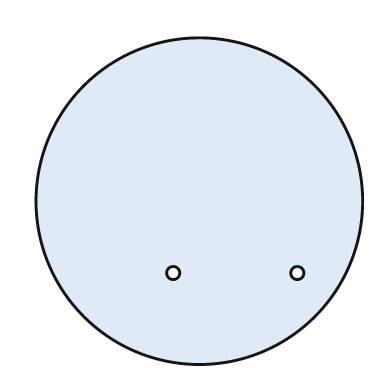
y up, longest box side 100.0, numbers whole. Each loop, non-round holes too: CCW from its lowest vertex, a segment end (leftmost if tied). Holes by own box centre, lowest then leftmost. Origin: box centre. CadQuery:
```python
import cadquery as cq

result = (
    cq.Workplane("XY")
    .moveTo(0.0, 0.0)
    .circle(50.0)
    .moveTo(-8.0, -22.0)
    .circle(2.0)
    .moveTo(30.0, -22.0)
    .circle(2.0)
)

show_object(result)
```